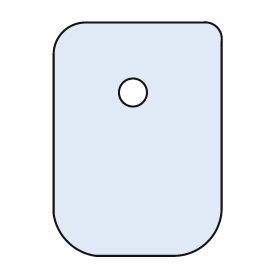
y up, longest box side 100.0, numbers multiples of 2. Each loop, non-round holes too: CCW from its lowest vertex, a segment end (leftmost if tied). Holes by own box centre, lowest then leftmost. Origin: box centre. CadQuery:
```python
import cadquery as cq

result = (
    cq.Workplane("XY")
    .moveTo(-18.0, -50.0)
    .lineTo(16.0, -50.0)
    .threePointArc((30.0, -44.0), (36.0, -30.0))
    .lineTo(36.0, 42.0)
    .threePointArc((34.0, 48.0), (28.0, 50.0))
    .lineTo(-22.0, 50.0)
    .threePointArc((-32.0, 46.0), (-36.0, 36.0))
    .lineTo(-36.0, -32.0)
    .threePointArc((-30.0, -44.0), (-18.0, -50.0))
    .close()
    .moveTo(-2.0, 20.0)
    .circle(6.0)
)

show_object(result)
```